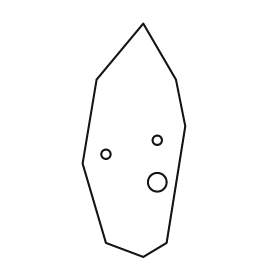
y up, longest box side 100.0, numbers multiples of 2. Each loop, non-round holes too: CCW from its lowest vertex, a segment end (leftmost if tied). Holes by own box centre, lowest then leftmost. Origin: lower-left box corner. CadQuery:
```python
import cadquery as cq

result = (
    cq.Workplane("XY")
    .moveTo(26.0, 0.0)
    .lineTo(36.0, 6.0)
    .lineTo(44.0, 56.0)
    .lineTo(40.0, 76.0)
    .lineTo(26.0, 100.0)
    .lineTo(6.0, 76.0)
    .lineTo(0.0, 40.0)
    .lineTo(10.0, 6.0)
    .close()
    .moveTo(32.0, 32.0)
    .circle(4.0)
    .moveTo(10.0, 44.0)
    .circle(2.0)
    .moveTo(32.0, 50.0)
    .circle(2.0)
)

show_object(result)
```